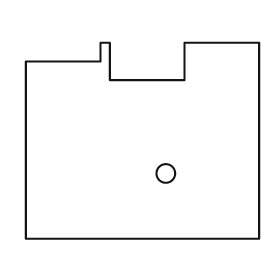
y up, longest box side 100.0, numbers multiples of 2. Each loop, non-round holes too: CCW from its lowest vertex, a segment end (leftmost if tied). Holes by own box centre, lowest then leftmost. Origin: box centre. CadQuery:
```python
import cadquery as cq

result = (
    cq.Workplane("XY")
    .moveTo(-50.0, -42.0)
    .lineTo(50.0, -42.0)
    .lineTo(50.0, 42.0)
    .lineTo(18.0, 42.0)
    .lineTo(18.0, 26.0)
    .lineTo(-14.0, 26.0)
    .lineTo(-14.0, 42.0)
    .lineTo(-18.0, 42.0)
    .lineTo(-18.0, 34.0)
    .lineTo(-50.0, 34.0)
    .close()
    .moveTo(10.0, -14.0)
    .circle(4.0)
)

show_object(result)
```